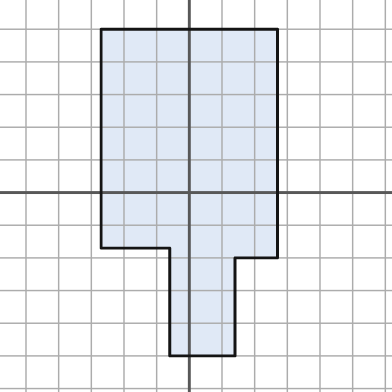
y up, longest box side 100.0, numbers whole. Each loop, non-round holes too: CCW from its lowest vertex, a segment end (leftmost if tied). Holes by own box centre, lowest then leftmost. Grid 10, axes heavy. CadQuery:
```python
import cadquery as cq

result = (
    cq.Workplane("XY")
    .moveTo(-6.0, -50.0)
    .lineTo(14.0, -50.0)
    .lineTo(14.0, -20.0)
    .lineTo(27.0, -20.0)
    .lineTo(27.0, 50.0)
    .lineTo(-27.0, 50.0)
    .lineTo(-27.0, -17.0)
    .lineTo(-6.0, -17.0)
    .close()
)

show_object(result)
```